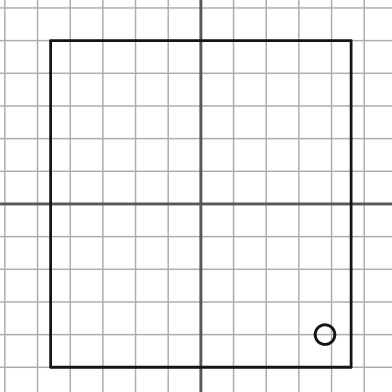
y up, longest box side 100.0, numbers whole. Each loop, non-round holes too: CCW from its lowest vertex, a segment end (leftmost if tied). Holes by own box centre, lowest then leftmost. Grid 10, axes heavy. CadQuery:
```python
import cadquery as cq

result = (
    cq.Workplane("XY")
    .moveTo(-46.0, -50.0)
    .lineTo(46.0, -50.0)
    .lineTo(46.0, 50.0)
    .lineTo(-46.0, 50.0)
    .close()
    .moveTo(38.0, -40.0)
    .circle(3.0)
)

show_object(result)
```